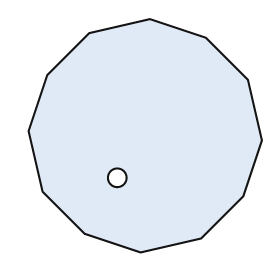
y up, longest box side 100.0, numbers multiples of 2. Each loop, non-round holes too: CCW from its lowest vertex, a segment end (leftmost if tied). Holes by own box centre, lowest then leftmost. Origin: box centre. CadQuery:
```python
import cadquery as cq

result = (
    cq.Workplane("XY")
    .moveTo(-2.0, -50.0)
    .lineTo(24.0, -44.0)
    .lineTo(42.0, -26.0)
    .lineTo(50.0, -2.0)
    .lineTo(44.0, 24.0)
    .lineTo(26.0, 42.0)
    .lineTo(2.0, 50.0)
    .lineTo(-24.0, 44.0)
    .lineTo(-42.0, 26.0)
    .lineTo(-50.0, 2.0)
    .lineTo(-44.0, -24.0)
    .lineTo(-26.0, -42.0)
    .close()
    .moveTo(-12.0, -18.0)
    .circle(4.0)
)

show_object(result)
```